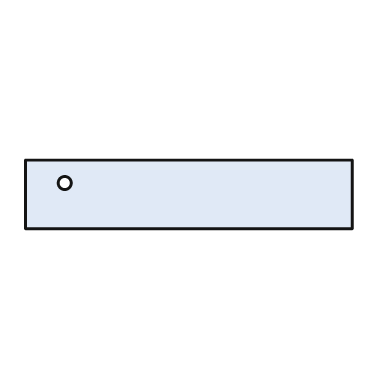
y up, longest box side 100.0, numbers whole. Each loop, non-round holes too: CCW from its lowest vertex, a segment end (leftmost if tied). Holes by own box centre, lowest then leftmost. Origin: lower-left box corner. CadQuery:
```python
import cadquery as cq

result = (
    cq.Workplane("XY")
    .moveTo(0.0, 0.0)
    .lineTo(100.0, 0.0)
    .lineTo(100.0, 21.0)
    .lineTo(0.0, 21.0)
    .close()
    .moveTo(12.0, 14.0)
    .circle(2.0)
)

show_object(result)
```